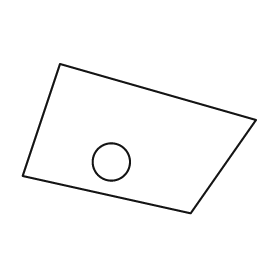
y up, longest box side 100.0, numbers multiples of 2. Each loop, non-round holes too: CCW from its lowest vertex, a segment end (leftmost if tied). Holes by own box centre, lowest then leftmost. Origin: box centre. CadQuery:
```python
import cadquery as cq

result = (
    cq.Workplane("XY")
    .moveTo(22.0, -32.0)
    .lineTo(50.0, 8.0)
    .lineTo(-34.0, 32.0)
    .lineTo(-50.0, -16.0)
    .close()
    .moveTo(-12.0, -10.0)
    .circle(8.0)
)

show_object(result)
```